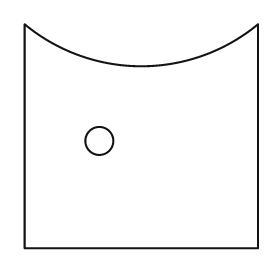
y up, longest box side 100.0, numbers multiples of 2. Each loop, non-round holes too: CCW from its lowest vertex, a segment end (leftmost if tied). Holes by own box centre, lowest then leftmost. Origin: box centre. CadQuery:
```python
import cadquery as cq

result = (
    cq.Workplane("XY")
    .moveTo(-50.0, -48.0)
    .lineTo(50.0, -48.0)
    .lineTo(50.0, 48.0)
    .threePointArc((0.0, 30.0), (-50.0, 48.0))
    .close()
    .moveTo(-18.0, -2.0)
    .circle(6.0)
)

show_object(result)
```